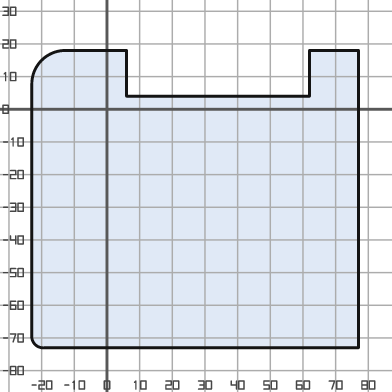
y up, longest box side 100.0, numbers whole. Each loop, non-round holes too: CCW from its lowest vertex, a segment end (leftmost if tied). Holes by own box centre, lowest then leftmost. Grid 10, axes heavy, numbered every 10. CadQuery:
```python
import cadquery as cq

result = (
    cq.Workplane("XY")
    .moveTo(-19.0, -73.0)
    .lineTo(77.0, -73.0)
    .lineTo(77.0, 18.0)
    .lineTo(62.0, 18.0)
    .lineTo(62.0, 4.0)
    .lineTo(6.0, 4.0)
    .lineTo(6.0, 18.0)
    .lineTo(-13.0, 18.0)
    .threePointArc((-20.0, 15.0), (-23.0, 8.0))
    .lineTo(-23.0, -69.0)
    .threePointArc((-22.0, -72.0), (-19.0, -73.0))
    .close()
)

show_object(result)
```